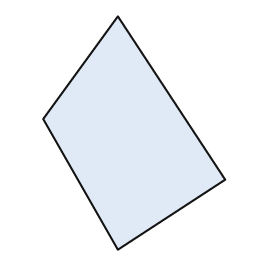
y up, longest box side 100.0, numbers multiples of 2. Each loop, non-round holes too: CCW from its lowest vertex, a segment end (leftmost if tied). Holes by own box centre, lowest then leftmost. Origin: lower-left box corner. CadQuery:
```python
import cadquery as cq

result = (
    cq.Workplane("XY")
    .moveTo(32.0, 0.0)
    .lineTo(78.0, 30.0)
    .lineTo(32.0, 100.0)
    .lineTo(0.0, 56.0)
    .close()
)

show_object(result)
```